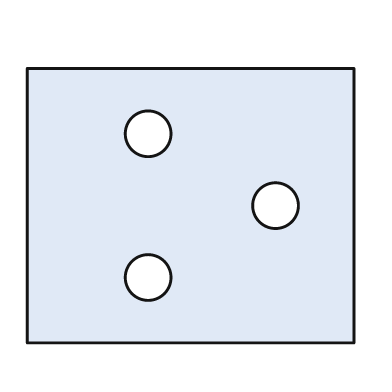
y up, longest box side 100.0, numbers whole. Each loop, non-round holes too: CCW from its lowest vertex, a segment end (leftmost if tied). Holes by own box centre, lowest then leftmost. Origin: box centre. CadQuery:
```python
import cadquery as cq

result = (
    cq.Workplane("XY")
    .moveTo(-50.0, -42.0)
    .lineTo(50.0, -42.0)
    .lineTo(50.0, 42.0)
    .lineTo(-50.0, 42.0)
    .close()
    .moveTo(-13.0, -22.0)
    .circle(7.0)
    .moveTo(26.0, 0.0)
    .circle(7.0)
    .moveTo(-13.0, 22.0)
    .circle(7.0)
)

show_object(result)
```